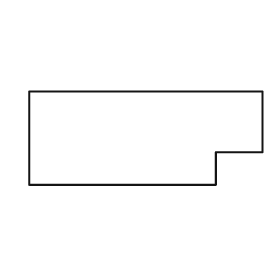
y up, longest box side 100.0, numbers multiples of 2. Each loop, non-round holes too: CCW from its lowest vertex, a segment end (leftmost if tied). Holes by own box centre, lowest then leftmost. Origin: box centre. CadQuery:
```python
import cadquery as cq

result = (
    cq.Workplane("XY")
    .moveTo(-50.0, -20.0)
    .lineTo(30.0, -20.0)
    .lineTo(30.0, -6.0)
    .lineTo(50.0, -6.0)
    .lineTo(50.0, 20.0)
    .lineTo(-50.0, 20.0)
    .close()
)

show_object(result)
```